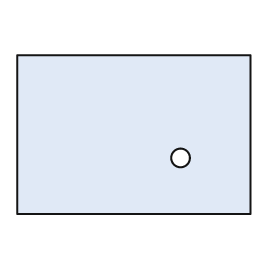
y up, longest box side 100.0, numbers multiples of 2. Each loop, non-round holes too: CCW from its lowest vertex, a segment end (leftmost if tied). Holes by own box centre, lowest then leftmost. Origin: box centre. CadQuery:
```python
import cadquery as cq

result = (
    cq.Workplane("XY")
    .moveTo(-50.0, -34.0)
    .lineTo(50.0, -34.0)
    .lineTo(50.0, 34.0)
    .lineTo(-50.0, 34.0)
    .close()
    .moveTo(20.0, -10.0)
    .circle(4.0)
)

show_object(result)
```